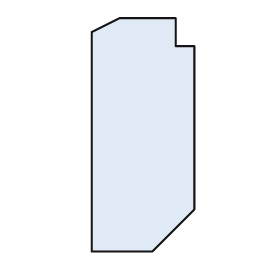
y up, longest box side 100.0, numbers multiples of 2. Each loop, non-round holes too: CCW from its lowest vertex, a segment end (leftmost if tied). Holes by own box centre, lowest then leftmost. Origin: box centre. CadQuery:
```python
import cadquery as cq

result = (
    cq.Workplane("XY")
    .moveTo(-22.0, -50.0)
    .lineTo(4.0, -50.0)
    .lineTo(22.0, -32.0)
    .lineTo(22.0, 38.0)
    .lineTo(14.0, 38.0)
    .lineTo(14.0, 50.0)
    .lineTo(-10.0, 50.0)
    .lineTo(-22.0, 44.0)
    .close()
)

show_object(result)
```